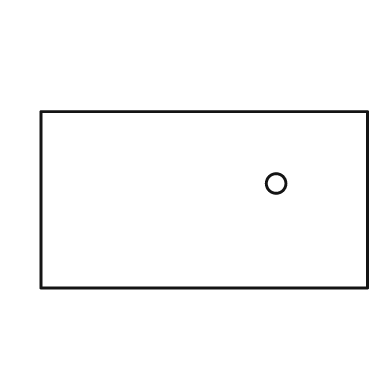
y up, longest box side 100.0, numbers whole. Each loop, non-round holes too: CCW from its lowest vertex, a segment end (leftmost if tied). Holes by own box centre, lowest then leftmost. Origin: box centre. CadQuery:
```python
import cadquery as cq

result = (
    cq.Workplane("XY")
    .moveTo(-50.0, -27.0)
    .lineTo(50.0, -27.0)
    .lineTo(50.0, 27.0)
    .lineTo(-50.0, 27.0)
    .close()
    .moveTo(22.0, 5.0)
    .circle(3.0)
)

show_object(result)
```